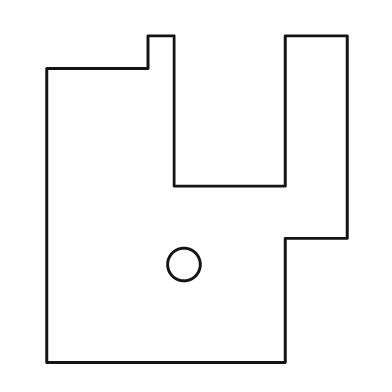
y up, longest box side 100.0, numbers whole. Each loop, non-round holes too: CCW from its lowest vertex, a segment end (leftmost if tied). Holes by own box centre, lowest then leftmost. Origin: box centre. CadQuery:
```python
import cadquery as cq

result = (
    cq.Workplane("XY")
    .moveTo(-46.0, -50.0)
    .lineTo(27.0, -50.0)
    .lineTo(27.0, -12.0)
    .lineTo(46.0, -12.0)
    .lineTo(46.0, 50.0)
    .lineTo(27.0, 50.0)
    .lineTo(27.0, 4.0)
    .lineTo(-7.0, 4.0)
    .lineTo(-7.0, 50.0)
    .lineTo(-15.0, 50.0)
    .lineTo(-15.0, 40.0)
    .lineTo(-46.0, 40.0)
    .close()
    .moveTo(-4.0, -20.0)
    .circle(5.0)
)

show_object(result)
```